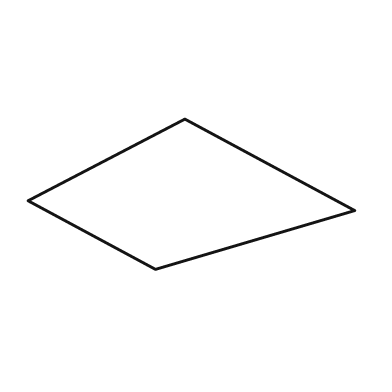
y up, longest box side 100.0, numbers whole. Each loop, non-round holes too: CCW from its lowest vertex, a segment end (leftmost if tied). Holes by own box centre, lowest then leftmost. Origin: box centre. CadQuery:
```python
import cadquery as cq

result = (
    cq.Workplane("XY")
    .moveTo(-11.0, -23.0)
    .lineTo(50.0, -5.0)
    .lineTo(-2.0, 23.0)
    .lineTo(-50.0, -2.0)
    .close()
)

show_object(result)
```